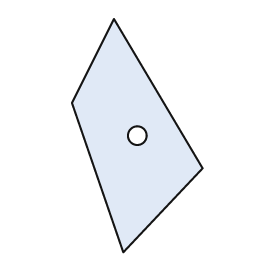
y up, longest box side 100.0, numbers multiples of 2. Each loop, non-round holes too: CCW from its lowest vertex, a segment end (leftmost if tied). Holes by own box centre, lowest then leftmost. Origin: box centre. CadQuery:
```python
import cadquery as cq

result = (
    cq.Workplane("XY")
    .moveTo(-6.0, -50.0)
    .lineTo(28.0, -14.0)
    .lineTo(-10.0, 50.0)
    .lineTo(-28.0, 14.0)
    .close()
    .moveTo(0.0, 0.0)
    .circle(4.0)
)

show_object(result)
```